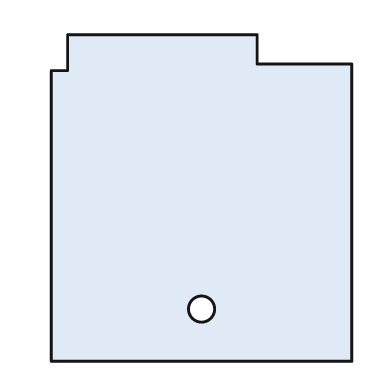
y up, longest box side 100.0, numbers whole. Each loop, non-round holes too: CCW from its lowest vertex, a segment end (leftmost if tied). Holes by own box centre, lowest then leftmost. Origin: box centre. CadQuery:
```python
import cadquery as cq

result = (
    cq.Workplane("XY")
    .moveTo(-46.0, -50.0)
    .lineTo(46.0, -50.0)
    .lineTo(46.0, 41.0)
    .lineTo(17.0, 41.0)
    .lineTo(17.0, 50.0)
    .lineTo(-41.0, 50.0)
    .lineTo(-41.0, 39.0)
    .lineTo(-46.0, 39.0)
    .close()
    .moveTo(0.0, -34.0)
    .circle(4.0)
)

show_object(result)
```